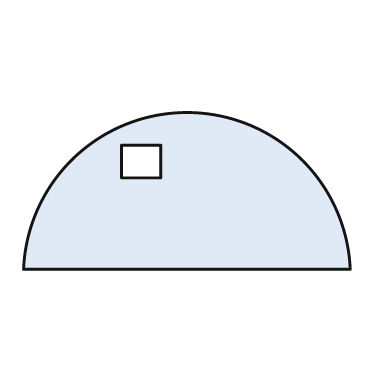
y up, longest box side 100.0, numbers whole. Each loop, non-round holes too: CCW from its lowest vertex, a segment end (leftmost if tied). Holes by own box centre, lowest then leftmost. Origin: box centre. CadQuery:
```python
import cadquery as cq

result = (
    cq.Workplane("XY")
    .moveTo(-50.0, -24.0)
    .lineTo(50.0, -24.0)
    .threePointArc((0.0, 24.0), (-50.0, -24.0))
    .close()
    .moveTo(-20.0, 4.0)
    .lineTo(-8.0, 4.0)
    .lineTo(-8.0, 14.0)
    .lineTo(-20.0, 14.0)
    .close()
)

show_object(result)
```